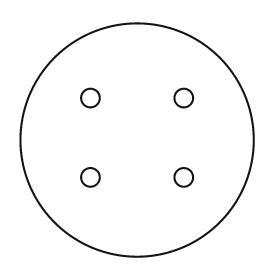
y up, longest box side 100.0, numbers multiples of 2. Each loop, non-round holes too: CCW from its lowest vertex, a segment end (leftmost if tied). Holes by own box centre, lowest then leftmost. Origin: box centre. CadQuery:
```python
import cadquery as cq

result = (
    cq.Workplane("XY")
    .moveTo(0.0, 0.0)
    .circle(50.0)
    .moveTo(-20.0, -16.0)
    .circle(4.0)
    .moveTo(20.0, -16.0)
    .circle(4.0)
    .moveTo(-20.0, 18.0)
    .circle(4.0)
    .moveTo(20.0, 18.0)
    .circle(4.0)
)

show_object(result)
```